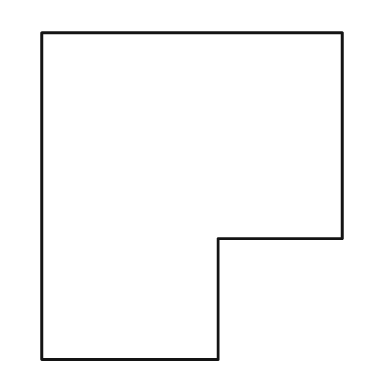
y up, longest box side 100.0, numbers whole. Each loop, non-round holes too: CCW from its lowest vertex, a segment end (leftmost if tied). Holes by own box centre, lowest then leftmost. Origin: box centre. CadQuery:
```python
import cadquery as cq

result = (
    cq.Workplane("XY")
    .moveTo(-46.0, -50.0)
    .lineTo(8.0, -50.0)
    .lineTo(8.0, -13.0)
    .lineTo(46.0, -13.0)
    .lineTo(46.0, 50.0)
    .lineTo(-46.0, 50.0)
    .close()
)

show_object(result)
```